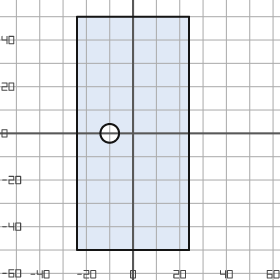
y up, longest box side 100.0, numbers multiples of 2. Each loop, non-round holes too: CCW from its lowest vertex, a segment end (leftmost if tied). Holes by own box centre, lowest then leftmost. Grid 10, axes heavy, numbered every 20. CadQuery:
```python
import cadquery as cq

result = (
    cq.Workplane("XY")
    .moveTo(-24.0, -50.0)
    .lineTo(24.0, -50.0)
    .lineTo(24.0, 50.0)
    .lineTo(-24.0, 50.0)
    .close()
    .moveTo(-10.0, 0.0)
    .circle(4.0)
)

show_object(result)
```